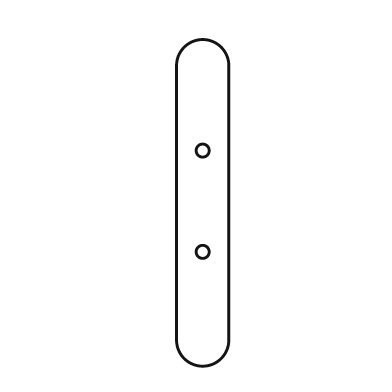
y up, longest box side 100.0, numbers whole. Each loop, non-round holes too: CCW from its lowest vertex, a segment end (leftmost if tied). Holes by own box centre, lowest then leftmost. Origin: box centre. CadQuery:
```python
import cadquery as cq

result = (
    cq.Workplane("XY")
    .moveTo(-8.0, -42.0)
    .threePointArc((0.0, -50.0), (8.0, -42.0))
    .lineTo(8.0, 42.0)
    .threePointArc((0.0, 50.0), (-8.0, 42.0))
    .close()
    .moveTo(0.0, -15.0)
    .circle(2.0)
    .moveTo(0.0, 16.0)
    .circle(2.0)
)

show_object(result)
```